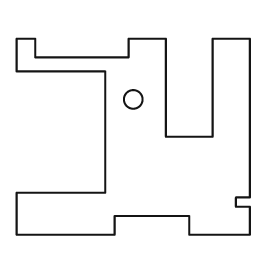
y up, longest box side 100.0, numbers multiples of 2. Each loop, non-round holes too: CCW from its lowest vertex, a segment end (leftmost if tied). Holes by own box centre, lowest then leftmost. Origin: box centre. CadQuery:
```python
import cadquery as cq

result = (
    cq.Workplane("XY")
    .moveTo(-50.0, -42.0)
    .lineTo(-8.0, -42.0)
    .lineTo(-8.0, -34.0)
    .lineTo(24.0, -34.0)
    .lineTo(24.0, -42.0)
    .lineTo(50.0, -42.0)
    .lineTo(50.0, -30.0)
    .lineTo(44.0, -30.0)
    .lineTo(44.0, -26.0)
    .lineTo(50.0, -26.0)
    .lineTo(50.0, 42.0)
    .lineTo(34.0, 42.0)
    .lineTo(34.0, 0.0)
    .lineTo(14.0, 0.0)
    .lineTo(14.0, 42.0)
    .lineTo(-2.0, 42.0)
    .lineTo(-2.0, 34.0)
    .lineTo(-42.0, 34.0)
    .lineTo(-42.0, 42.0)
    .lineTo(-50.0, 42.0)
    .lineTo(-50.0, 28.0)
    .lineTo(-12.0, 28.0)
    .lineTo(-12.0, -24.0)
    .lineTo(-50.0, -24.0)
    .close()
    .moveTo(0.0, 16.0)
    .circle(4.0)
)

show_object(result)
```